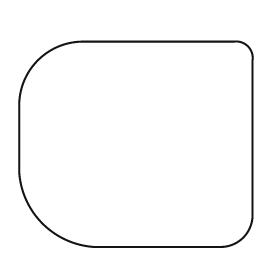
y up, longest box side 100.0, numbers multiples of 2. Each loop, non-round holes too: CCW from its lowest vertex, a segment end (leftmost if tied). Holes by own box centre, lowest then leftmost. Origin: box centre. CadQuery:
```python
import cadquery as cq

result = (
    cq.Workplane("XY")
    .moveTo(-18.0, -44.0)
    .lineTo(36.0, -44.0)
    .threePointArc((46.0, -40.0), (50.0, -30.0))
    .lineTo(50.0, 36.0)
    .threePointArc((48.0, 42.0), (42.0, 44.0))
    .lineTo(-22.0, 44.0)
    .threePointArc((-42.0, 36.0), (-50.0, 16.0))
    .lineTo(-50.0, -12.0)
    .threePointArc((-40.0, -34.0), (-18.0, -44.0))
    .close()
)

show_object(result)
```